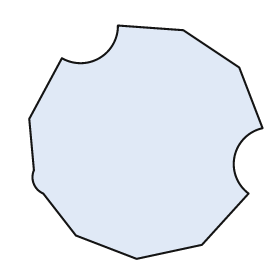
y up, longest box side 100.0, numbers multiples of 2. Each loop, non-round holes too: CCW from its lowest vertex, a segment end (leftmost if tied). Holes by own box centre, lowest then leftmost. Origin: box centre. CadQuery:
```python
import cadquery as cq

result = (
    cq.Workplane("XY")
    .moveTo(-4.0, -50.0)
    .lineTo(24.0, -44.0)
    .lineTo(44.0, -22.0)
    .threePointArc((38.0, -6.0), (50.0, 6.0))
    .lineTo(40.0, 32.0)
    .lineTo(16.0, 48.0)
    .lineTo(-12.0, 50.0)
    .threePointArc((-20.0, 36.0), (-36.0, 36.0))
    .lineTo(-50.0, 10.0)
    .lineTo(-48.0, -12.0)
    .threePointArc((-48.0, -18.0), (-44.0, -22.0))
    .lineTo(-30.0, -40.0)
    .close()
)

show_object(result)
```